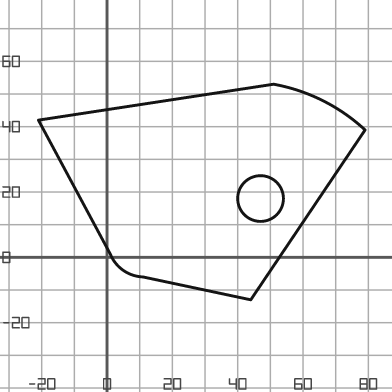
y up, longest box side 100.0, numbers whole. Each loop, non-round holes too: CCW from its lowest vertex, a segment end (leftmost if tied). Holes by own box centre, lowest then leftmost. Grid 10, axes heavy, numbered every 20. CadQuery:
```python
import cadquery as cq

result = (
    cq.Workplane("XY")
    .moveTo(44.0, -13.0)
    .lineTo(79.0, 39.0)
    .threePointArc((66.0, 48.0), (51.0, 53.0))
    .lineTo(-21.0, 42.0)
    .lineTo(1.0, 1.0)
    .threePointArc((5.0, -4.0), (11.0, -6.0))
    .close()
    .moveTo(47.0, 18.0)
    .circle(7.0)
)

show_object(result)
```